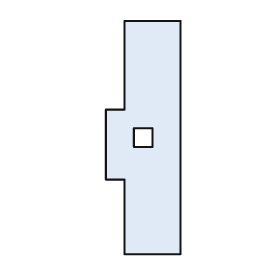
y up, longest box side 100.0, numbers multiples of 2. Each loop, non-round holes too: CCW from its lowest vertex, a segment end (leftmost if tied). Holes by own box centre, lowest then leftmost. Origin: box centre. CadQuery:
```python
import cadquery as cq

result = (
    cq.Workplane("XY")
    .moveTo(-8.0, -50.0)
    .lineTo(16.0, -50.0)
    .lineTo(16.0, 50.0)
    .lineTo(-8.0, 50.0)
    .lineTo(-8.0, 12.0)
    .lineTo(-16.0, 12.0)
    .lineTo(-16.0, -18.0)
    .lineTo(-8.0, -18.0)
    .close()
    .moveTo(-4.0, -4.0)
    .lineTo(4.0, -4.0)
    .lineTo(4.0, 4.0)
    .lineTo(-4.0, 4.0)
    .close()
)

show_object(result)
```